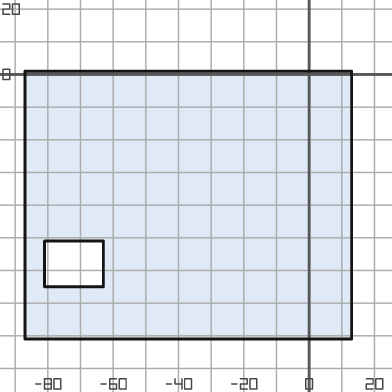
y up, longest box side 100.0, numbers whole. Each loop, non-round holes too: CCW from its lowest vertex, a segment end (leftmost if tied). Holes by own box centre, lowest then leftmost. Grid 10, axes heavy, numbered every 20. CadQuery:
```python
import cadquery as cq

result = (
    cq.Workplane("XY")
    .moveTo(-87.0, -81.0)
    .lineTo(13.0, -81.0)
    .lineTo(13.0, 1.0)
    .lineTo(-87.0, 1.0)
    .close()
    .moveTo(-81.0, -65.0)
    .lineTo(-63.0, -65.0)
    .lineTo(-63.0, -51.0)
    .lineTo(-81.0, -51.0)
    .close()
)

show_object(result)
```